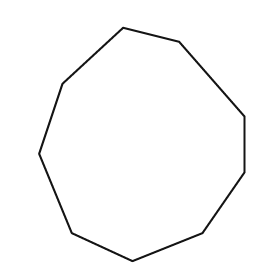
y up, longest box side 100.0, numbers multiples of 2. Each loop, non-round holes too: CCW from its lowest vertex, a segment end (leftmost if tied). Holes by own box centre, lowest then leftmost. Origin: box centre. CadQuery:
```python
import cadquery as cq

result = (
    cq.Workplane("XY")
    .moveTo(-4.0, -50.0)
    .lineTo(26.0, -38.0)
    .lineTo(44.0, -12.0)
    .lineTo(44.0, 12.0)
    .lineTo(16.0, 44.0)
    .lineTo(-8.0, 50.0)
    .lineTo(-34.0, 26.0)
    .lineTo(-44.0, -4.0)
    .lineTo(-30.0, -38.0)
    .close()
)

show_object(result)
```